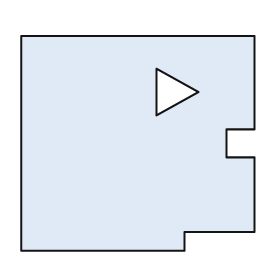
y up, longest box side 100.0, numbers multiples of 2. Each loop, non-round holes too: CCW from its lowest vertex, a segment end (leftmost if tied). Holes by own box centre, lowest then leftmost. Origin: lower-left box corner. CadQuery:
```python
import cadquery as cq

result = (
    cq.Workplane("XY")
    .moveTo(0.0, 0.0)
    .lineTo(70.0, 0.0)
    .lineTo(70.0, 8.0)
    .lineTo(100.0, 8.0)
    .lineTo(100.0, 40.0)
    .lineTo(88.0, 40.0)
    .lineTo(88.0, 52.0)
    .lineTo(100.0, 52.0)
    .lineTo(100.0, 92.0)
    .lineTo(0.0, 92.0)
    .close()
    .moveTo(58.0, 58.0)
    .lineTo(76.0, 68.0)
    .lineTo(58.0, 78.0)
    .close()
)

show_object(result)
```